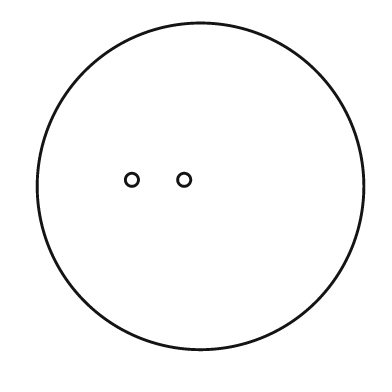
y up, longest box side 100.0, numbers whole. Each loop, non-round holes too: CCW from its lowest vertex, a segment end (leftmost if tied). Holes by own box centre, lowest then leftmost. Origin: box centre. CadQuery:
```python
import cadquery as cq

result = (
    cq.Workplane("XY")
    .moveTo(0.0, 0.0)
    .circle(50.0)
    .moveTo(-21.0, 2.0)
    .circle(2.0)
    .moveTo(-5.0, 2.0)
    .circle(2.0)
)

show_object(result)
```